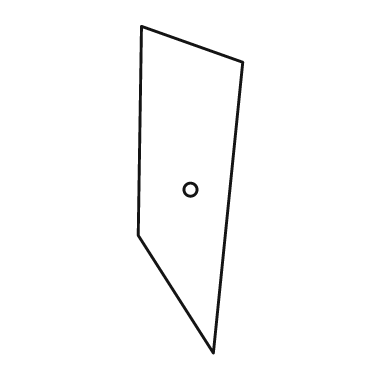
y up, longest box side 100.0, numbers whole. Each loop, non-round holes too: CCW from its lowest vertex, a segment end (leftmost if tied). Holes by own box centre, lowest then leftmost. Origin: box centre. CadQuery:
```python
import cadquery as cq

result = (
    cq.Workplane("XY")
    .moveTo(7.0, -50.0)
    .lineTo(16.0, 39.0)
    .lineTo(-15.0, 50.0)
    .lineTo(-16.0, -14.0)
    .close()
    .moveTo(0.0, 0.0)
    .circle(2.0)
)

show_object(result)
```